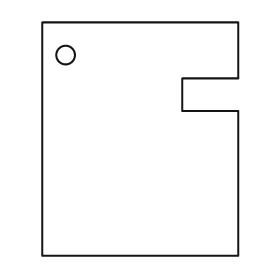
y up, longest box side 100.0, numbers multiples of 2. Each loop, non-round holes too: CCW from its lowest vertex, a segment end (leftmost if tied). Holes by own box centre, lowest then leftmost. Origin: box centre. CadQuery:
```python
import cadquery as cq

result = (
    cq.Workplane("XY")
    .moveTo(-42.0, -50.0)
    .lineTo(42.0, -50.0)
    .lineTo(42.0, 12.0)
    .lineTo(18.0, 12.0)
    .lineTo(18.0, 26.0)
    .lineTo(42.0, 26.0)
    .lineTo(42.0, 50.0)
    .lineTo(-42.0, 50.0)
    .close()
    .moveTo(-32.0, 36.0)
    .circle(4.0)
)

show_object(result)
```